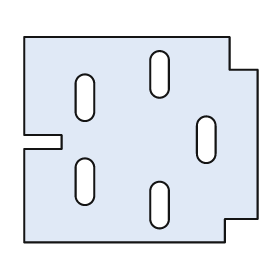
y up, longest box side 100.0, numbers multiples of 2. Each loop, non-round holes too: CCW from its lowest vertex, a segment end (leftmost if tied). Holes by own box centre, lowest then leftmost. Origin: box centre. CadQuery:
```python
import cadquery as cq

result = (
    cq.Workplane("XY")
    .moveTo(-50.0, -44.0)
    .lineTo(36.0, -44.0)
    .lineTo(36.0, -34.0)
    .lineTo(50.0, -34.0)
    .lineTo(50.0, 30.0)
    .lineTo(38.0, 30.0)
    .lineTo(38.0, 44.0)
    .lineTo(-50.0, 44.0)
    .lineTo(-50.0, 2.0)
    .lineTo(-34.0, 2.0)
    .lineTo(-34.0, -4.0)
    .lineTo(-50.0, -4.0)
    .close()
    .moveTo(4.0, -34.0)
    .threePointArc((8.0, -38.0), (12.0, -34.0))
    .lineTo(12.0, -22.0)
    .threePointArc((8.0, -18.0), (4.0, -22.0))
    .close()
    .moveTo(-28.0, -24.0)
    .threePointArc((-24.0, -28.0), (-20.0, -24.0))
    .lineTo(-20.0, -12.0)
    .threePointArc((-24.0, -8.0), (-28.0, -12.0))
    .close()
    .moveTo(24.0, -6.0)
    .threePointArc((28.0, -10.0), (32.0, -6.0))
    .lineTo(32.0, 6.0)
    .threePointArc((28.0, 10.0), (24.0, 6.0))
    .close()
    .moveTo(-28.0, 12.0)
    .threePointArc((-24.0, 8.0), (-20.0, 12.0))
    .lineTo(-20.0, 24.0)
    .threePointArc((-24.0, 28.0), (-28.0, 24.0))
    .close()
    .moveTo(4.0, 22.0)
    .threePointArc((8.0, 18.0), (12.0, 22.0))
    .lineTo(12.0, 34.0)
    .threePointArc((8.0, 38.0), (4.0, 34.0))
    .close()
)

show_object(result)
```